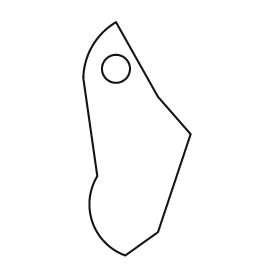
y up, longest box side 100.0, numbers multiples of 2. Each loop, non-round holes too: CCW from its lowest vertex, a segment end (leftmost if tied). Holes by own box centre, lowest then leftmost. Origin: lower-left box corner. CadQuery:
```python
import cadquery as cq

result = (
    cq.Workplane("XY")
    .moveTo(18.0, 0.0)
    .lineTo(32.0, 10.0)
    .lineTo(46.0, 52.0)
    .lineTo(32.0, 68.0)
    .lineTo(14.0, 100.0)
    .threePointArc((4.0, 90.0), (0.0, 76.0))
    .lineTo(6.0, 34.0)
    .threePointArc((4.0, 14.0), (18.0, 0.0))
    .close()
    .moveTo(14.0, 80.0)
    .circle(6.0)
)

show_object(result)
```